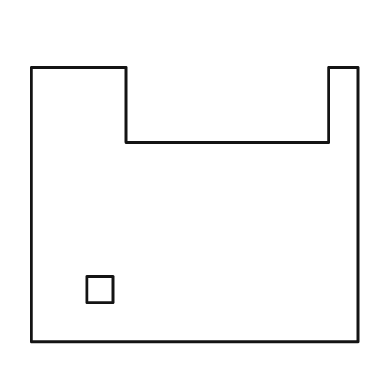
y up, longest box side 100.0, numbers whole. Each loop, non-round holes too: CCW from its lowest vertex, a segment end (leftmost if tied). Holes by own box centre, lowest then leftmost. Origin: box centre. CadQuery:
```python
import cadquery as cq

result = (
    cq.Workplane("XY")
    .moveTo(-50.0, -42.0)
    .lineTo(50.0, -42.0)
    .lineTo(50.0, 42.0)
    .lineTo(41.0, 42.0)
    .lineTo(41.0, 19.0)
    .lineTo(-21.0, 19.0)
    .lineTo(-21.0, 42.0)
    .lineTo(-50.0, 42.0)
    .close()
    .moveTo(-33.0, -30.0)
    .lineTo(-25.0, -30.0)
    .lineTo(-25.0, -22.0)
    .lineTo(-33.0, -22.0)
    .close()
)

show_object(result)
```